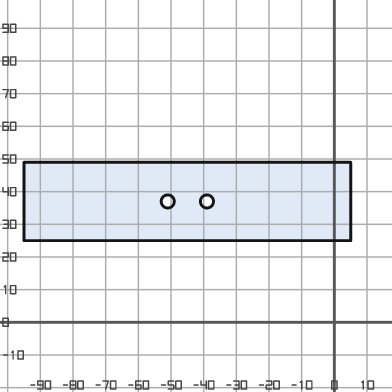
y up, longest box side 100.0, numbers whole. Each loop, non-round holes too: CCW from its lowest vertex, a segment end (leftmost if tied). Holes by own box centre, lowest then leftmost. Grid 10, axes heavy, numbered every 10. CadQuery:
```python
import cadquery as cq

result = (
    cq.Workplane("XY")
    .moveTo(-95.0, 25.0)
    .lineTo(5.0, 25.0)
    .lineTo(5.0, 49.0)
    .lineTo(-95.0, 49.0)
    .close()
    .moveTo(-51.0, 37.0)
    .circle(2.0)
    .moveTo(-39.0, 37.0)
    .circle(2.0)
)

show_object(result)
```